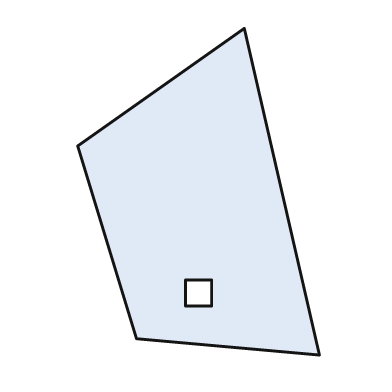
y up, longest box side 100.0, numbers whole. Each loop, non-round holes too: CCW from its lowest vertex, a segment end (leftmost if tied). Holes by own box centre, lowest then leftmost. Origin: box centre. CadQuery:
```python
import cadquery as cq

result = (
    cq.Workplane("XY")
    .moveTo(37.0, -50.0)
    .lineTo(14.0, 50.0)
    .lineTo(-37.0, 14.0)
    .lineTo(-19.0, -45.0)
    .close()
    .moveTo(-4.0, -35.0)
    .lineTo(4.0, -35.0)
    .lineTo(4.0, -27.0)
    .lineTo(-4.0, -27.0)
    .close()
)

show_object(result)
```